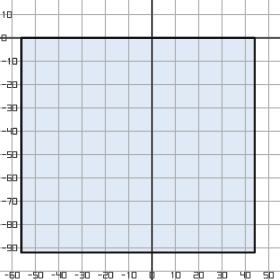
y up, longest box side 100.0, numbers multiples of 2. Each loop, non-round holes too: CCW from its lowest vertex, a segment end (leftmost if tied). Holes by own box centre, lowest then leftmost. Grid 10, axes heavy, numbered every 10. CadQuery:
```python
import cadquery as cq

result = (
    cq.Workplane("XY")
    .moveTo(-56.0, -92.0)
    .lineTo(44.0, -92.0)
    .lineTo(44.0, 0.0)
    .lineTo(-56.0, 0.0)
    .close()
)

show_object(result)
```